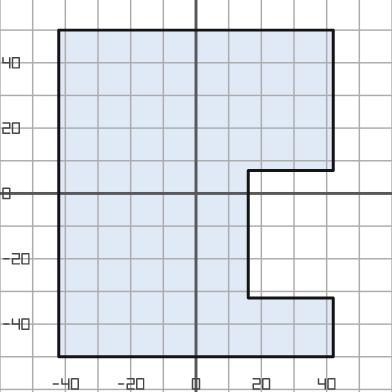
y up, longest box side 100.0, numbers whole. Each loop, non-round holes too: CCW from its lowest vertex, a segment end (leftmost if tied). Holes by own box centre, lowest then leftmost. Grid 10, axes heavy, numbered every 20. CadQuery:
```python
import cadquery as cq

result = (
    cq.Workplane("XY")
    .moveTo(-42.0, -50.0)
    .lineTo(42.0, -50.0)
    .lineTo(42.0, -32.0)
    .lineTo(16.0, -32.0)
    .lineTo(16.0, 7.0)
    .lineTo(42.0, 7.0)
    .lineTo(42.0, 50.0)
    .lineTo(-42.0, 50.0)
    .close()
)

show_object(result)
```